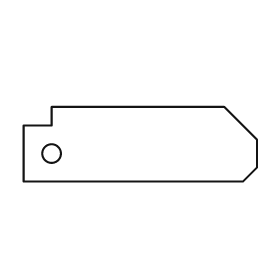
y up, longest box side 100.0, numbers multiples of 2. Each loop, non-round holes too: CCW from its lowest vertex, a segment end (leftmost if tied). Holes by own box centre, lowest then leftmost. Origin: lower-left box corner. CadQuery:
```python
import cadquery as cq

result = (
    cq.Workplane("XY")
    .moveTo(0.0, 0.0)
    .lineTo(94.0, 0.0)
    .lineTo(100.0, 6.0)
    .lineTo(100.0, 18.0)
    .lineTo(86.0, 32.0)
    .lineTo(12.0, 32.0)
    .lineTo(12.0, 24.0)
    .lineTo(0.0, 24.0)
    .close()
    .moveTo(12.0, 12.0)
    .circle(4.0)
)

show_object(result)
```